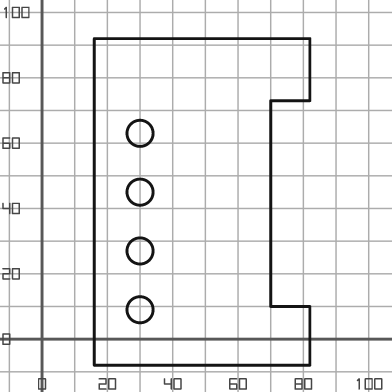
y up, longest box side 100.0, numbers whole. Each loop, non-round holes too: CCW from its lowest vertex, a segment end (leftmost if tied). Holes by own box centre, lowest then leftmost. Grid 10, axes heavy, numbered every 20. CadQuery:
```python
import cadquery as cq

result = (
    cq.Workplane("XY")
    .moveTo(16.0, -8.0)
    .lineTo(82.0, -8.0)
    .lineTo(82.0, 10.0)
    .lineTo(70.0, 10.0)
    .lineTo(70.0, 73.0)
    .lineTo(82.0, 73.0)
    .lineTo(82.0, 92.0)
    .lineTo(16.0, 92.0)
    .close()
    .moveTo(30.0, 9.0)
    .circle(4.0)
    .moveTo(30.0, 27.0)
    .circle(4.0)
    .moveTo(30.0, 45.0)
    .circle(4.0)
    .moveTo(30.0, 63.0)
    .circle(4.0)
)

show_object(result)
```